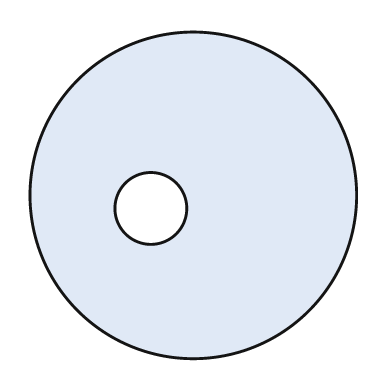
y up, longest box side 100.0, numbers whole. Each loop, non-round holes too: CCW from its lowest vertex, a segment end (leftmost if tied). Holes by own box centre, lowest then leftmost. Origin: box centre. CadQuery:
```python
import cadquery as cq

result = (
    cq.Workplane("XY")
    .moveTo(0.0, 0.0)
    .circle(50.0)
    .moveTo(-13.0, -4.0)
    .circle(11.0)
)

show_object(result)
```